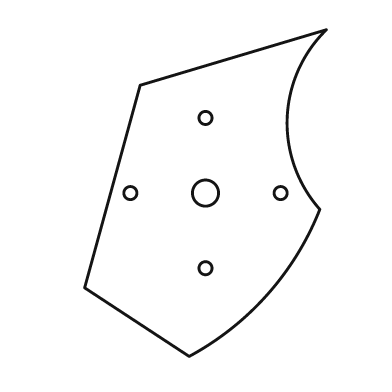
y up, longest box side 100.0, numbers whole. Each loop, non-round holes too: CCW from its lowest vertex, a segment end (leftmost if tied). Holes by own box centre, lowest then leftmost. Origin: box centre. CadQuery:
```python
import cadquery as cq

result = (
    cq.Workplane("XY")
    .moveTo(-5.0, -50.0)
    .threePointArc((19.0, -31.0), (35.0, -5.0))
    .threePointArc((25.0, 23.0), (37.0, 50.0))
    .lineTo(-20.0, 33.0)
    .lineTo(-37.0, -29.0)
    .close()
    .moveTo(0.0, -23.0)
    .circle(2.0)
    .moveTo(-23.0, 0.0)
    .circle(2.0)
    .moveTo(0.0, 0.0)
    .circle(4.0)
    .moveTo(23.0, 0.0)
    .circle(2.0)
    .moveTo(0.0, 23.0)
    .circle(2.0)
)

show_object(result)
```